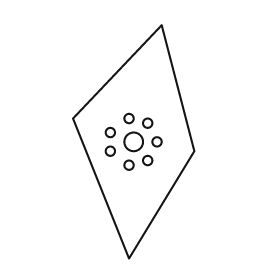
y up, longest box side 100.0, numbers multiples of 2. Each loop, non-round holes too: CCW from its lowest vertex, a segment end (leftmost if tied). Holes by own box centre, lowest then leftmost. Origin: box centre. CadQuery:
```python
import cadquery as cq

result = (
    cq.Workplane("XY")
    .moveTo(-2.0, -50.0)
    .lineTo(26.0, -4.0)
    .lineTo(12.0, 50.0)
    .lineTo(-26.0, 10.0)
    .close()
    .moveTo(-2.0, -10.0)
    .circle(2.0)
    .moveTo(6.0, -8.0)
    .circle(2.0)
    .moveTo(-10.0, -4.0)
    .circle(2.0)
    .moveTo(0.0, 0.0)
    .circle(4.0)
    .moveTo(10.0, 0.0)
    .circle(2.0)
    .moveTo(-10.0, 4.0)
    .circle(2.0)
    .moveTo(6.0, 8.0)
    .circle(2.0)
    .moveTo(-2.0, 10.0)
    .circle(2.0)
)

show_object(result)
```